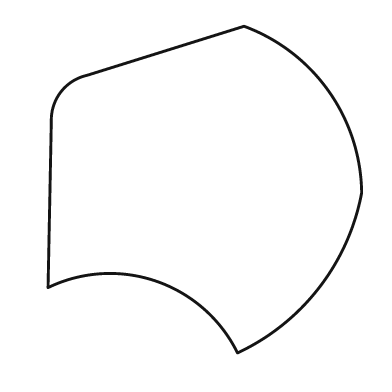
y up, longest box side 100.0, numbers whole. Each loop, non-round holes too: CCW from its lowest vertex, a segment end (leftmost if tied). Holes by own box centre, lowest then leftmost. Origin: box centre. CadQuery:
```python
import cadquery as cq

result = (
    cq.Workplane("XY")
    .moveTo(10.0, -50.0)
    .threePointArc((35.0, -30.0), (48.0, -1.0))
    .threePointArc((38.0, 30.0), (12.0, 50.0))
    .lineTo(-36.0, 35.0)
    .threePointArc((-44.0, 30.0), (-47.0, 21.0))
    .lineTo(-48.0, -30.0)
    .threePointArc((-15.0, -28.0), (10.0, -50.0))
    .close()
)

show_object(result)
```